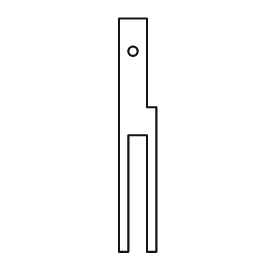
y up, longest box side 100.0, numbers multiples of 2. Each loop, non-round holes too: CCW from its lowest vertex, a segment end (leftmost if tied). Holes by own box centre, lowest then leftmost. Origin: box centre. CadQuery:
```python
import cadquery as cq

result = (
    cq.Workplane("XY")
    .moveTo(-8.0, -50.0)
    .lineTo(-4.0, -50.0)
    .lineTo(-4.0, 0.0)
    .lineTo(4.0, 0.0)
    .lineTo(4.0, -50.0)
    .lineTo(8.0, -50.0)
    .lineTo(8.0, 12.0)
    .lineTo(4.0, 12.0)
    .lineTo(4.0, 50.0)
    .lineTo(-8.0, 50.0)
    .close()
    .moveTo(-2.0, 36.0)
    .circle(2.0)
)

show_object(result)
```